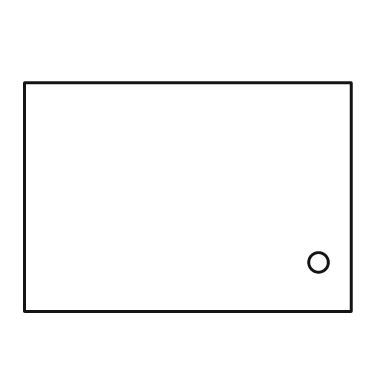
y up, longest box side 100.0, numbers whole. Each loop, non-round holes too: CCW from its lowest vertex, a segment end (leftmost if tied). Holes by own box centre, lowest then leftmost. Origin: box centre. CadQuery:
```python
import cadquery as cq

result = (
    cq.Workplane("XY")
    .moveTo(-50.0, -35.0)
    .lineTo(50.0, -35.0)
    .lineTo(50.0, 35.0)
    .lineTo(-50.0, 35.0)
    .close()
    .moveTo(40.0, -20.0)
    .circle(3.0)
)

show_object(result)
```